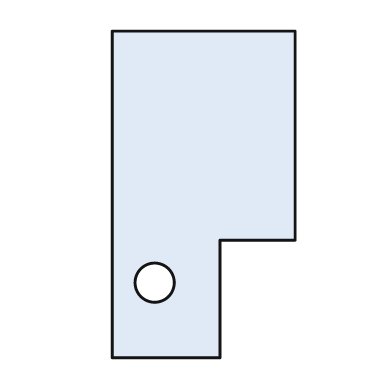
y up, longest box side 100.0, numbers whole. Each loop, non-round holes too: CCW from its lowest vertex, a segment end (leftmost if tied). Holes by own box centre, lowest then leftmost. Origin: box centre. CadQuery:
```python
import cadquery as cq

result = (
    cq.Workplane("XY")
    .moveTo(-28.0, -50.0)
    .lineTo(5.0, -50.0)
    .lineTo(5.0, -14.0)
    .lineTo(28.0, -14.0)
    .lineTo(28.0, 50.0)
    .lineTo(-28.0, 50.0)
    .close()
    .moveTo(-15.0, -27.0)
    .circle(6.0)
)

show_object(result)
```